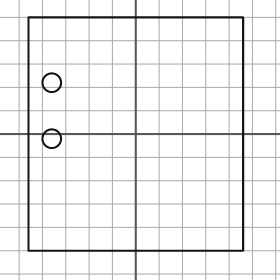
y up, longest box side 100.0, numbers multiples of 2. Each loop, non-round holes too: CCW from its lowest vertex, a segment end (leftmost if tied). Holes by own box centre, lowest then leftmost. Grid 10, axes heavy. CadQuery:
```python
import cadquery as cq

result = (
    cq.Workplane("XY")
    .moveTo(-46.0, -50.0)
    .lineTo(46.0, -50.0)
    .lineTo(46.0, 50.0)
    .lineTo(-46.0, 50.0)
    .close()
    .moveTo(-36.0, -2.0)
    .circle(4.0)
    .moveTo(-36.0, 22.0)
    .circle(4.0)
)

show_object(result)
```